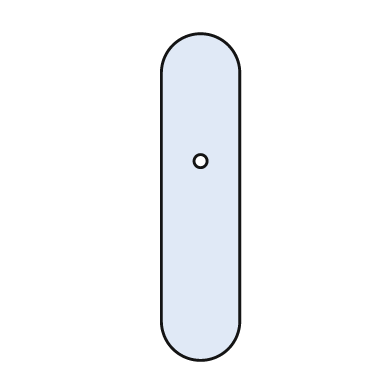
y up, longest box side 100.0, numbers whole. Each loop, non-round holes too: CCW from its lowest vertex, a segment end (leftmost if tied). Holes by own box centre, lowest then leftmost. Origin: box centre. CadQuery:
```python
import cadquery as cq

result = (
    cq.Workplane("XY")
    .moveTo(-12.0, -38.0)
    .threePointArc((0.0, -50.0), (12.0, -38.0))
    .lineTo(12.0, 38.0)
    .threePointArc((0.0, 50.0), (-12.0, 38.0))
    .close()
    .moveTo(0.0, 11.0)
    .circle(2.0)
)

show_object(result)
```